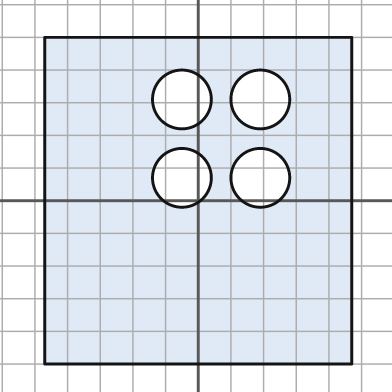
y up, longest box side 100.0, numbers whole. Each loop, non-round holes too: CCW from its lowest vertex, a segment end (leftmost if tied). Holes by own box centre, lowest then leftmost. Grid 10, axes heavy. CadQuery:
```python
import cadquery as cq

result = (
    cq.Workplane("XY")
    .moveTo(-47.0, -50.0)
    .lineTo(47.0, -50.0)
    .lineTo(47.0, 50.0)
    .lineTo(-47.0, 50.0)
    .close()
    .moveTo(-5.0, 7.0)
    .circle(9.0)
    .moveTo(19.0, 7.0)
    .circle(9.0)
    .moveTo(-5.0, 31.0)
    .circle(9.0)
    .moveTo(19.0, 31.0)
    .circle(9.0)
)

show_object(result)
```